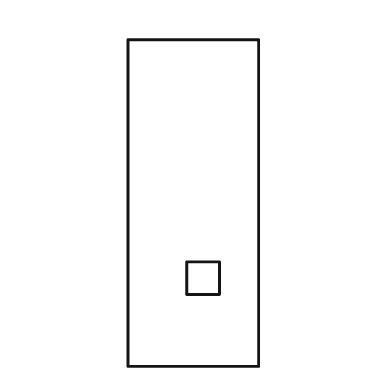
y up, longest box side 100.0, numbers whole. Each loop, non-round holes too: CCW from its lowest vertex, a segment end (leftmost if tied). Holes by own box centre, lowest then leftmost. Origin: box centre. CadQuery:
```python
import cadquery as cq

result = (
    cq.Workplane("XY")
    .moveTo(-20.0, -50.0)
    .lineTo(20.0, -50.0)
    .lineTo(20.0, 50.0)
    .lineTo(-20.0, 50.0)
    .close()
    .moveTo(-2.0, -28.0)
    .lineTo(8.0, -28.0)
    .lineTo(8.0, -18.0)
    .lineTo(-2.0, -18.0)
    .close()
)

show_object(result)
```